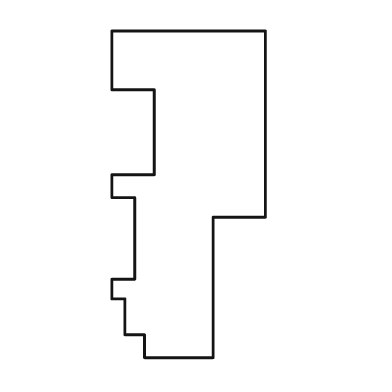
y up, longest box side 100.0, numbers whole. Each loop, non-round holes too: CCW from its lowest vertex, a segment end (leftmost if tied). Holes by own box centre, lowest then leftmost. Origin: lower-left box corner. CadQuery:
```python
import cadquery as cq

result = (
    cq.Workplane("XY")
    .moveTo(10.0, 0.0)
    .lineTo(31.0, 0.0)
    .lineTo(31.0, 43.0)
    .lineTo(47.0, 43.0)
    .lineTo(47.0, 100.0)
    .lineTo(0.0, 100.0)
    .lineTo(0.0, 82.0)
    .lineTo(13.0, 82.0)
    .lineTo(13.0, 56.0)
    .lineTo(0.0, 56.0)
    .lineTo(0.0, 49.0)
    .lineTo(7.0, 49.0)
    .lineTo(7.0, 24.0)
    .lineTo(0.0, 24.0)
    .lineTo(0.0, 18.0)
    .lineTo(4.0, 18.0)
    .lineTo(4.0, 7.0)
    .lineTo(10.0, 7.0)
    .close()
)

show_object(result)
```